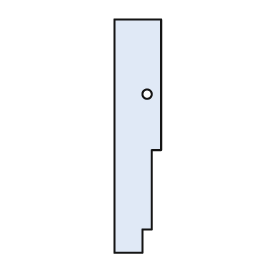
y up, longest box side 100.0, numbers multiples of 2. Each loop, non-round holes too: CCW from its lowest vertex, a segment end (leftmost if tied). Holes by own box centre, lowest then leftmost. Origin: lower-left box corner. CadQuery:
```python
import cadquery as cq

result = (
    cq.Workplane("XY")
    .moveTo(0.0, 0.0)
    .lineTo(12.0, 0.0)
    .lineTo(12.0, 10.0)
    .lineTo(16.0, 10.0)
    .lineTo(16.0, 44.0)
    .lineTo(20.0, 44.0)
    .lineTo(20.0, 100.0)
    .lineTo(0.0, 100.0)
    .close()
    .moveTo(14.0, 68.0)
    .circle(2.0)
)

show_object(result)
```